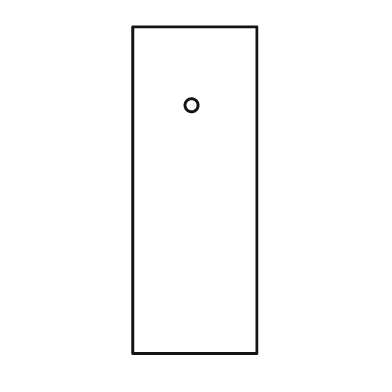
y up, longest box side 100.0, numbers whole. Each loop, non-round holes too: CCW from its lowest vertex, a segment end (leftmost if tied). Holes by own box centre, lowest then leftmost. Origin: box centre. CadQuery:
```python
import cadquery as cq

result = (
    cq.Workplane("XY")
    .moveTo(-19.0, -50.0)
    .lineTo(19.0, -50.0)
    .lineTo(19.0, 50.0)
    .lineTo(-19.0, 50.0)
    .close()
    .moveTo(-1.0, 26.0)
    .circle(2.0)
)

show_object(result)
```